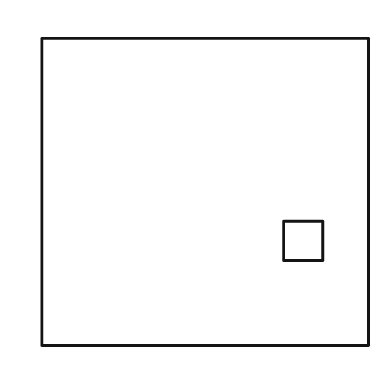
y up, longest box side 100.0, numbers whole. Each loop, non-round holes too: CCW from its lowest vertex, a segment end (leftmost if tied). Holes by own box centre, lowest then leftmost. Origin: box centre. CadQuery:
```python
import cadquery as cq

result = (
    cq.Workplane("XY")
    .moveTo(-50.0, -47.0)
    .lineTo(50.0, -47.0)
    .lineTo(50.0, 47.0)
    .lineTo(-50.0, 47.0)
    .close()
    .moveTo(24.0, -21.0)
    .lineTo(36.0, -21.0)
    .lineTo(36.0, -9.0)
    .lineTo(24.0, -9.0)
    .close()
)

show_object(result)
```